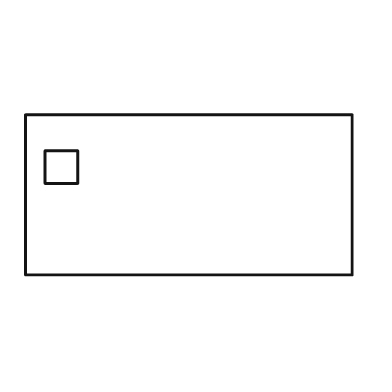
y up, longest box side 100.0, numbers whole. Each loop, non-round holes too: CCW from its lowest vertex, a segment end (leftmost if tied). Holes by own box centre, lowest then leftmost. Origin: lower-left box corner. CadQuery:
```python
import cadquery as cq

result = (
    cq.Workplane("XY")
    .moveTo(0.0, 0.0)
    .lineTo(100.0, 0.0)
    .lineTo(100.0, 49.0)
    .lineTo(0.0, 49.0)
    .close()
    .moveTo(6.0, 28.0)
    .lineTo(16.0, 28.0)
    .lineTo(16.0, 38.0)
    .lineTo(6.0, 38.0)
    .close()
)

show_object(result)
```